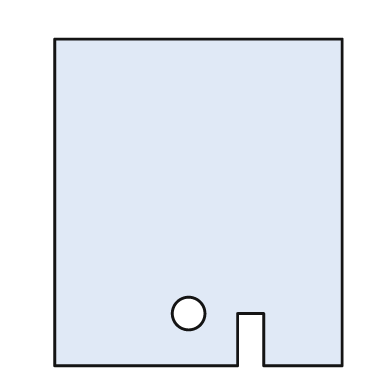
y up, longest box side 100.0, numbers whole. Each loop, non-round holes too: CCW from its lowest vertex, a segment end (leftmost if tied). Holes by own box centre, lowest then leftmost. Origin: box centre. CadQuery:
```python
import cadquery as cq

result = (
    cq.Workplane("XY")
    .moveTo(-44.0, -50.0)
    .lineTo(12.0, -50.0)
    .lineTo(12.0, -34.0)
    .lineTo(20.0, -34.0)
    .lineTo(20.0, -50.0)
    .lineTo(44.0, -50.0)
    .lineTo(44.0, 50.0)
    .lineTo(-44.0, 50.0)
    .close()
    .moveTo(-3.0, -34.0)
    .circle(5.0)
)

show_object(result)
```